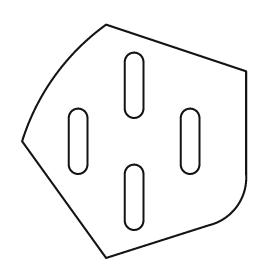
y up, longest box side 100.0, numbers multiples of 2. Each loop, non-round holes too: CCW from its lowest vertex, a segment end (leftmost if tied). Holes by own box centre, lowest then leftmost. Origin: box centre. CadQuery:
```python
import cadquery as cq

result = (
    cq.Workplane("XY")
    .moveTo(-12.0, -50.0)
    .lineTo(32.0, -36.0)
    .threePointArc((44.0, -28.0), (48.0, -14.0))
    .lineTo(48.0, 30.0)
    .lineTo(-12.0, 50.0)
    .threePointArc((-34.0, 28.0), (-48.0, 0.0))
    .close()
    .moveTo(-4.0, -34.0)
    .threePointArc((0.0, -38.0), (4.0, -34.0))
    .lineTo(4.0, -14.0)
    .threePointArc((0.0, -10.0), (-4.0, -14.0))
    .close()
    .moveTo(-28.0, -10.0)
    .threePointArc((-24.0, -14.0), (-20.0, -10.0))
    .lineTo(-20.0, 10.0)
    .threePointArc((-24.0, 14.0), (-28.0, 10.0))
    .close()
    .moveTo(20.0, -10.0)
    .threePointArc((24.0, -14.0), (28.0, -10.0))
    .lineTo(28.0, 10.0)
    .threePointArc((24.0, 14.0), (20.0, 10.0))
    .close()
    .moveTo(-4.0, 14.0)
    .threePointArc((0.0, 10.0), (4.0, 14.0))
    .lineTo(4.0, 34.0)
    .threePointArc((0.0, 38.0), (-4.0, 34.0))
    .close()
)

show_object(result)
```